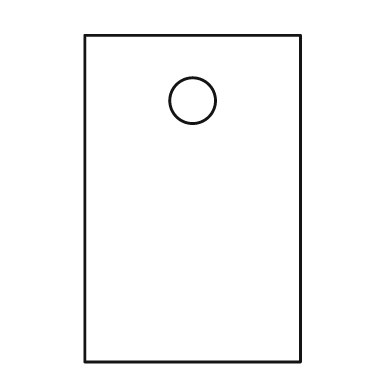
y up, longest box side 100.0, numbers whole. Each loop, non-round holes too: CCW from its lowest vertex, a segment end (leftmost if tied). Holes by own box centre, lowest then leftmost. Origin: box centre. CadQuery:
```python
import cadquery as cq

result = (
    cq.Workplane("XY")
    .moveTo(-33.0, -50.0)
    .lineTo(33.0, -50.0)
    .lineTo(33.0, 50.0)
    .lineTo(-33.0, 50.0)
    .close()
    .moveTo(0.0, 30.0)
    .circle(7.0)
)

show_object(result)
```